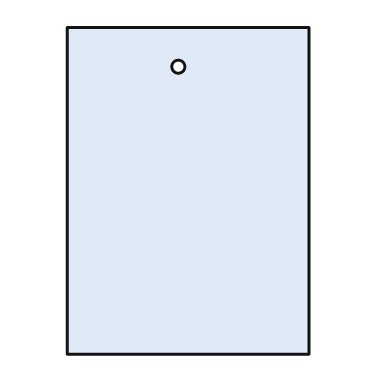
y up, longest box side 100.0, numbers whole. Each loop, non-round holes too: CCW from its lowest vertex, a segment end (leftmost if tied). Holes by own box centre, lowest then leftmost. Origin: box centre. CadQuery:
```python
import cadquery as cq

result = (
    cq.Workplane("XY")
    .moveTo(-37.0, -50.0)
    .lineTo(37.0, -50.0)
    .lineTo(37.0, 50.0)
    .lineTo(-37.0, 50.0)
    .close()
    .moveTo(-3.0, 38.0)
    .circle(2.0)
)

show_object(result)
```